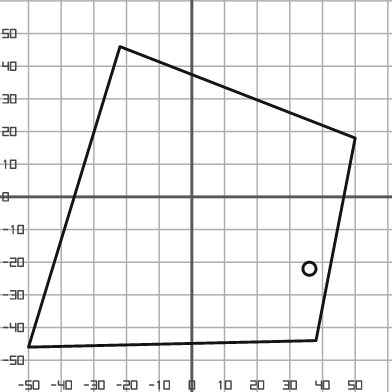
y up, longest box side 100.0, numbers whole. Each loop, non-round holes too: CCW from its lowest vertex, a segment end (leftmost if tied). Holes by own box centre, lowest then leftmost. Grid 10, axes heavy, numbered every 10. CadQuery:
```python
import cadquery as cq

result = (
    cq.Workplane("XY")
    .moveTo(-50.0, -46.0)
    .lineTo(38.0, -44.0)
    .lineTo(50.0, 18.0)
    .lineTo(-22.0, 46.0)
    .close()
    .moveTo(36.0, -22.0)
    .circle(2.0)
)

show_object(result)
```